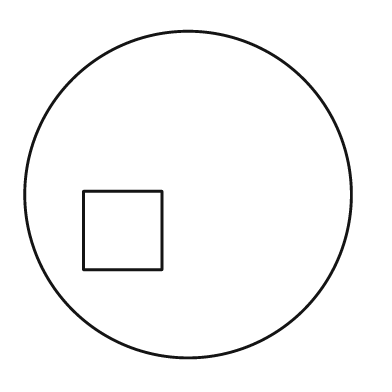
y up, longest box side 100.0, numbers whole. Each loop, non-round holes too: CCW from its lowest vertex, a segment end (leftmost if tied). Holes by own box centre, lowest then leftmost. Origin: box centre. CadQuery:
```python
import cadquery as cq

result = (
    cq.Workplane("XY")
    .moveTo(0.0, 0.0)
    .circle(50.0)
    .moveTo(-32.0, -23.0)
    .lineTo(-8.0, -23.0)
    .lineTo(-8.0, 1.0)
    .lineTo(-32.0, 1.0)
    .close()
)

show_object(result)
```